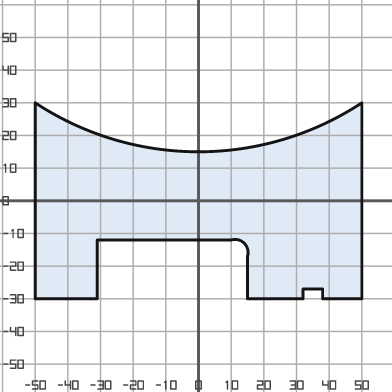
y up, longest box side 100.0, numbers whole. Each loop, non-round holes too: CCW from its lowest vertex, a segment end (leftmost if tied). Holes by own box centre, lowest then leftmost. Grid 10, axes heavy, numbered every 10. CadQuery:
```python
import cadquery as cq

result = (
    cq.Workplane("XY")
    .moveTo(-50.0, -30.0)
    .lineTo(-31.0, -30.0)
    .lineTo(-31.0, -12.0)
    .lineTo(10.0, -12.0)
    .threePointArc((14.0, -13.0), (15.0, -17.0))
    .lineTo(15.0, -30.0)
    .lineTo(32.0, -30.0)
    .lineTo(32.0, -27.0)
    .lineTo(38.0, -27.0)
    .lineTo(38.0, -30.0)
    .lineTo(50.0, -30.0)
    .lineTo(50.0, 30.0)
    .threePointArc((0.0, 15.0), (-50.0, 30.0))
    .close()
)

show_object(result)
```